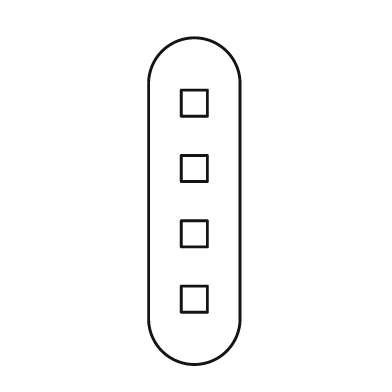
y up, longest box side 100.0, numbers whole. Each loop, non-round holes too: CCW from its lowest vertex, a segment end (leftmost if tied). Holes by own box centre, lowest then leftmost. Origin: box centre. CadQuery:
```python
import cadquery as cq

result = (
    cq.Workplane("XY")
    .moveTo(-14.0, -36.0)
    .threePointArc((0.0, -50.0), (14.0, -36.0))
    .lineTo(14.0, 36.0)
    .threePointArc((0.0, 50.0), (-14.0, 36.0))
    .close()
    .moveTo(-4.0, -34.0)
    .lineTo(4.0, -34.0)
    .lineTo(4.0, -26.0)
    .lineTo(-4.0, -26.0)
    .close()
    .moveTo(-4.0, -14.0)
    .lineTo(4.0, -14.0)
    .lineTo(4.0, -6.0)
    .lineTo(-4.0, -6.0)
    .close()
    .moveTo(-4.0, 6.0)
    .lineTo(4.0, 6.0)
    .lineTo(4.0, 14.0)
    .lineTo(-4.0, 14.0)
    .close()
    .moveTo(-4.0, 26.0)
    .lineTo(4.0, 26.0)
    .lineTo(4.0, 34.0)
    .lineTo(-4.0, 34.0)
    .close()
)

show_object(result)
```